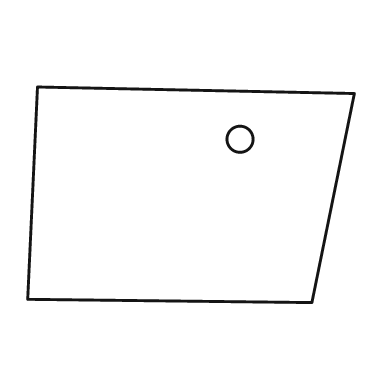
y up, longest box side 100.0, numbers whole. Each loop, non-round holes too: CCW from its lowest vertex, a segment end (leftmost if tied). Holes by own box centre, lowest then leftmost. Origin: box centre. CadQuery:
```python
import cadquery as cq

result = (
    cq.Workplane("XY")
    .moveTo(37.0, -33.0)
    .lineTo(50.0, 31.0)
    .lineTo(-47.0, 33.0)
    .lineTo(-50.0, -32.0)
    .close()
    .moveTo(15.0, 17.0)
    .circle(4.0)
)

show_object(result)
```